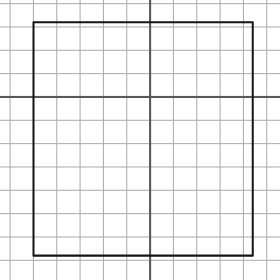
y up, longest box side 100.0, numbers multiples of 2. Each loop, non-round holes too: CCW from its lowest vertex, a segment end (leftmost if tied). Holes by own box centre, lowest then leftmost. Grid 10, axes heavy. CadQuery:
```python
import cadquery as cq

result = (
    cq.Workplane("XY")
    .moveTo(-50.0, -68.0)
    .lineTo(44.0, -68.0)
    .lineTo(44.0, 32.0)
    .lineTo(-50.0, 32.0)
    .close()
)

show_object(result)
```